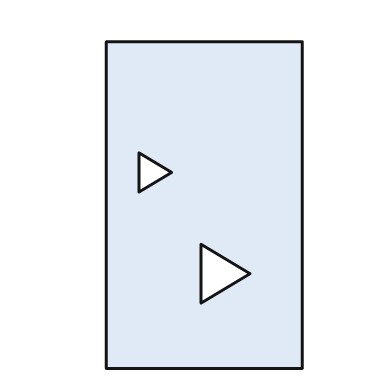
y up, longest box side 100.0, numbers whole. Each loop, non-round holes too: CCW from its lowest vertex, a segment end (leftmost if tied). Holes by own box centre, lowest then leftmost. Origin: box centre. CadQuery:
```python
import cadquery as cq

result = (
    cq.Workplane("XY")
    .moveTo(-30.0, -50.0)
    .lineTo(30.0, -50.0)
    .lineTo(30.0, 50.0)
    .lineTo(-30.0, 50.0)
    .close()
    .moveTo(-1.0, -30.0)
    .lineTo(14.0, -21.0)
    .lineTo(-1.0, -12.0)
    .close()
    .moveTo(-20.0, 4.0)
    .lineTo(-10.0, 10.0)
    .lineTo(-20.0, 16.0)
    .close()
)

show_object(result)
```